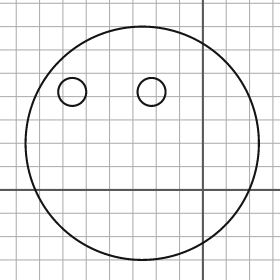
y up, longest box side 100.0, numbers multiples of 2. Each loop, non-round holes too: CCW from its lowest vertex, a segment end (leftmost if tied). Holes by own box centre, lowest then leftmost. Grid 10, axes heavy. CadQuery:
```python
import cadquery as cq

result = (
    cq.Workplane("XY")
    .moveTo(-26.0, 20.0)
    .circle(50.0)
    .moveTo(-56.0, 42.0)
    .circle(6.0)
    .moveTo(-22.0, 42.0)
    .circle(6.0)
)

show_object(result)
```